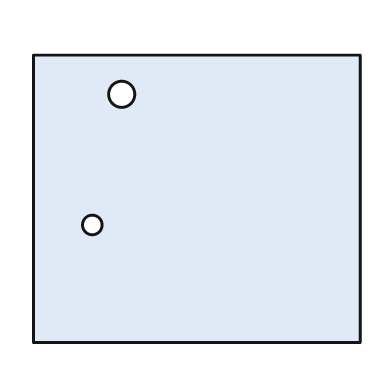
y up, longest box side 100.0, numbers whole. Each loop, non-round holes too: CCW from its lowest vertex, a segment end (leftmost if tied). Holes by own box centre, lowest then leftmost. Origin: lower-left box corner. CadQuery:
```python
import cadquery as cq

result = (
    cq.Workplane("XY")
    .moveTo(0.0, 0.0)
    .lineTo(100.0, 0.0)
    .lineTo(100.0, 88.0)
    .lineTo(0.0, 88.0)
    .close()
    .moveTo(18.0, 36.0)
    .circle(3.0)
    .moveTo(27.0, 76.0)
    .circle(4.0)
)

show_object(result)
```